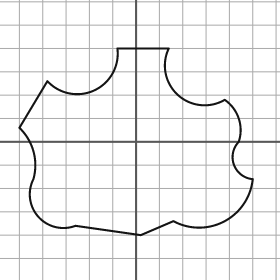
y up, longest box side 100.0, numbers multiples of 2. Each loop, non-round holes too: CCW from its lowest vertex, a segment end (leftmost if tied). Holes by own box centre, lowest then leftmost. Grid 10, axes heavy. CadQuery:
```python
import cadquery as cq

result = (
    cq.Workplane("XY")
    .moveTo(2.0, -40.0)
    .lineTo(16.0, -34.0)
    .threePointArc((38.0, -34.0), (50.0, -16.0))
    .threePointArc((42.0, -10.0), (44.0, 0.0))
    .threePointArc((44.0, 10.0), (38.0, 18.0))
    .threePointArc((18.0, 20.0), (14.0, 40.0))
    .lineTo(-8.0, 40.0)
    .threePointArc((-18.0, 22.0), (-38.0, 26.0))
    .lineTo(-50.0, 6.0)
    .threePointArc((-44.0, -4.0), (-44.0, -16.0))
    .threePointArc((-42.0, -32.0), (-26.0, -36.0))
    .close()
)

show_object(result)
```